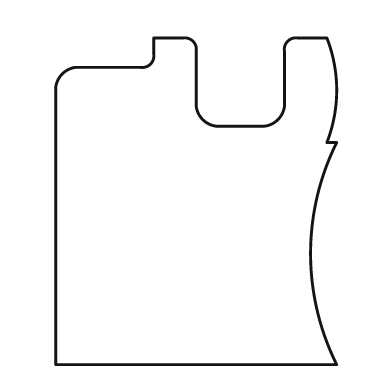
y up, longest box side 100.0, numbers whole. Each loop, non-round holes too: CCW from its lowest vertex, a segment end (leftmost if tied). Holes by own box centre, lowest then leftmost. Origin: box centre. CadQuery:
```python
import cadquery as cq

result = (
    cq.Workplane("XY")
    .moveTo(-43.0, -50.0)
    .lineTo(43.0, -50.0)
    .threePointArc((35.0, -16.0), (43.0, 18.0))
    .lineTo(40.0, 18.0)
    .threePointArc((43.0, 34.0), (40.0, 50.0))
    .lineTo(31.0, 50.0)
    .threePointArc((28.0, 49.0), (27.0, 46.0))
    .lineTo(27.0, 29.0)
    .threePointArc((25.0, 25.0), (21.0, 23.0))
    .lineTo(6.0, 23.0)
    .threePointArc((2.0, 25.0), (0.0, 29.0))
    .lineTo(0.0, 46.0)
    .threePointArc((-1.0, 49.0), (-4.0, 50.0))
    .lineTo(-13.0, 50.0)
    .lineTo(-13.0, 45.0)
    .threePointArc((-14.0, 42.0), (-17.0, 41.0))
    .lineTo(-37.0, 41.0)
    .threePointArc((-41.0, 39.0), (-43.0, 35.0))
    .close()
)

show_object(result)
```